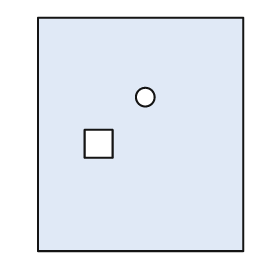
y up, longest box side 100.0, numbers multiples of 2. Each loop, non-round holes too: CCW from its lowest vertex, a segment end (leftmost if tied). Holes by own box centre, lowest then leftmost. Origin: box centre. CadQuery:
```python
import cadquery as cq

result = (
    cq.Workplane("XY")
    .moveTo(-44.0, -50.0)
    .lineTo(44.0, -50.0)
    .lineTo(44.0, 50.0)
    .lineTo(-44.0, 50.0)
    .close()
    .moveTo(-24.0, -10.0)
    .lineTo(-12.0, -10.0)
    .lineTo(-12.0, 2.0)
    .lineTo(-24.0, 2.0)
    .close()
    .moveTo(2.0, 16.0)
    .circle(4.0)
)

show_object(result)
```